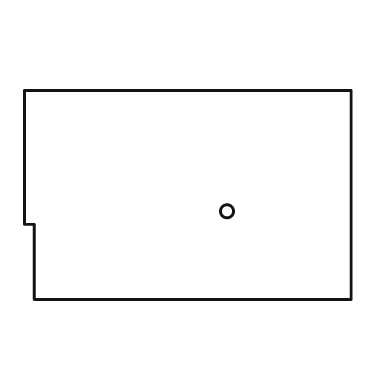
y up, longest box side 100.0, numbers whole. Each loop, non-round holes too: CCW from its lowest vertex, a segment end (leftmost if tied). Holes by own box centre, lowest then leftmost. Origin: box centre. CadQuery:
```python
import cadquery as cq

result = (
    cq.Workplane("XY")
    .moveTo(-47.0, -32.0)
    .lineTo(50.0, -32.0)
    .lineTo(50.0, 32.0)
    .lineTo(-50.0, 32.0)
    .lineTo(-50.0, -9.0)
    .lineTo(-47.0, -9.0)
    .close()
    .moveTo(12.0, -5.0)
    .circle(2.0)
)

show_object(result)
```